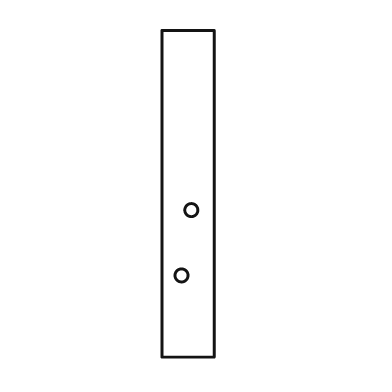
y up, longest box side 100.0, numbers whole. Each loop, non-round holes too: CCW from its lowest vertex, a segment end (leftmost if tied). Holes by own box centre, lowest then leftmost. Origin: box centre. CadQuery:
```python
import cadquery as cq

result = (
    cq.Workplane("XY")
    .moveTo(-8.0, -50.0)
    .lineTo(8.0, -50.0)
    .lineTo(8.0, 50.0)
    .lineTo(-8.0, 50.0)
    .close()
    .moveTo(-2.0, -25.0)
    .circle(2.0)
    .moveTo(1.0, -5.0)
    .circle(2.0)
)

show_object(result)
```